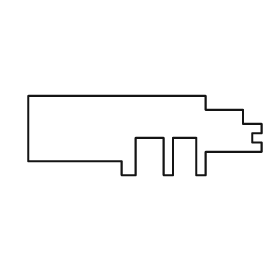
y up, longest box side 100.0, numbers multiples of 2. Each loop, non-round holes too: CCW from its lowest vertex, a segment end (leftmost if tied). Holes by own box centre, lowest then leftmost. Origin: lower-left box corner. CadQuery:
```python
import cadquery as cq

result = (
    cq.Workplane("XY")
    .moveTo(40.0, 0.0)
    .lineTo(46.0, 0.0)
    .lineTo(46.0, 16.0)
    .lineTo(58.0, 16.0)
    .lineTo(58.0, 0.0)
    .lineTo(62.0, 0.0)
    .lineTo(62.0, 16.0)
    .lineTo(72.0, 16.0)
    .lineTo(72.0, 0.0)
    .lineTo(76.0, 0.0)
    .lineTo(76.0, 10.0)
    .lineTo(100.0, 10.0)
    .lineTo(100.0, 14.0)
    .lineTo(96.0, 14.0)
    .lineTo(96.0, 18.0)
    .lineTo(100.0, 18.0)
    .lineTo(100.0, 22.0)
    .lineTo(92.0, 22.0)
    .lineTo(92.0, 28.0)
    .lineTo(76.0, 28.0)
    .lineTo(76.0, 34.0)
    .lineTo(0.0, 34.0)
    .lineTo(0.0, 6.0)
    .lineTo(40.0, 6.0)
    .close()
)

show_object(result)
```